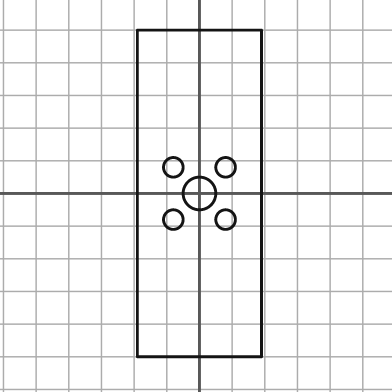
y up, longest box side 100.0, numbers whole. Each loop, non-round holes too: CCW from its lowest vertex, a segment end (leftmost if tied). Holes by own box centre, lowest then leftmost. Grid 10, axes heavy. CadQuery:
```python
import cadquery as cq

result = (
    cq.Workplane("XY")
    .moveTo(-19.0, -50.0)
    .lineTo(19.0, -50.0)
    .lineTo(19.0, 50.0)
    .lineTo(-19.0, 50.0)
    .close()
    .moveTo(-8.0, -8.0)
    .circle(3.0)
    .moveTo(8.0, -8.0)
    .circle(3.0)
    .moveTo(0.0, 0.0)
    .circle(5.0)
    .moveTo(-8.0, 8.0)
    .circle(3.0)
    .moveTo(8.0, 8.0)
    .circle(3.0)
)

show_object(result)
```